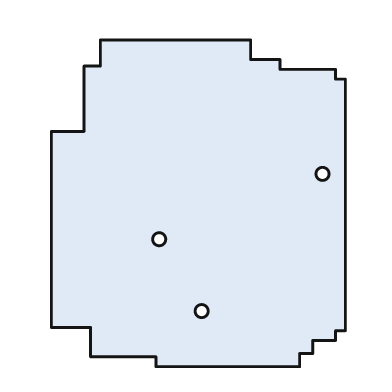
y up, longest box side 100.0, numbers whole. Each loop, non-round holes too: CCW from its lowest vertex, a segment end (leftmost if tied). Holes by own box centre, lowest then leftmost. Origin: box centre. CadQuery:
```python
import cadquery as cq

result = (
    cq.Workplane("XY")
    .moveTo(-13.0, -50.0)
    .lineTo(31.0, -50.0)
    .lineTo(31.0, -46.0)
    .lineTo(35.0, -46.0)
    .lineTo(35.0, -42.0)
    .lineTo(42.0, -42.0)
    .lineTo(42.0, -39.0)
    .lineTo(45.0, -39.0)
    .lineTo(45.0, 38.0)
    .lineTo(42.0, 38.0)
    .lineTo(42.0, 41.0)
    .lineTo(25.0, 41.0)
    .lineTo(25.0, 44.0)
    .lineTo(16.0, 44.0)
    .lineTo(16.0, 50.0)
    .lineTo(-30.0, 50.0)
    .lineTo(-30.0, 42.0)
    .lineTo(-35.0, 42.0)
    .lineTo(-35.0, 22.0)
    .lineTo(-45.0, 22.0)
    .lineTo(-45.0, -38.0)
    .lineTo(-33.0, -38.0)
    .lineTo(-33.0, -47.0)
    .lineTo(-13.0, -47.0)
    .close()
    .moveTo(1.0, -33.0)
    .circle(2.0)
    .moveTo(-12.0, -11.0)
    .circle(2.0)
    .moveTo(38.0, 9.0)
    .circle(2.0)
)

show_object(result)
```